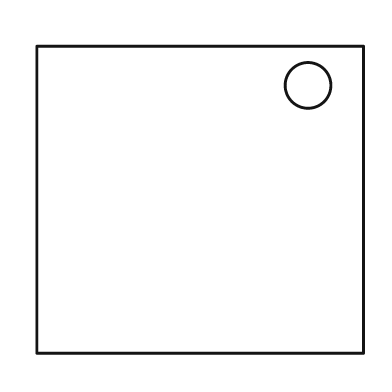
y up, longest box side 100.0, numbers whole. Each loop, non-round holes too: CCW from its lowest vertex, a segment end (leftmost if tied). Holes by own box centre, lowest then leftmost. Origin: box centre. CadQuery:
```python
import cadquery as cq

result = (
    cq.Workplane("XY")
    .moveTo(-50.0, -47.0)
    .lineTo(50.0, -47.0)
    .lineTo(50.0, 47.0)
    .lineTo(-50.0, 47.0)
    .close()
    .moveTo(33.0, 35.0)
    .circle(7.0)
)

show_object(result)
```